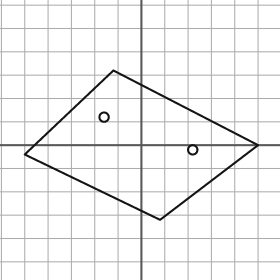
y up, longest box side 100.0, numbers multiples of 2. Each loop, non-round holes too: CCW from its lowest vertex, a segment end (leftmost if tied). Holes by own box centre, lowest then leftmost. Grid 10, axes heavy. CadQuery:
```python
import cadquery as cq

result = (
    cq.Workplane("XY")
    .moveTo(8.0, -32.0)
    .lineTo(50.0, 0.0)
    .lineTo(-12.0, 32.0)
    .lineTo(-50.0, -4.0)
    .close()
    .moveTo(22.0, -2.0)
    .circle(2.0)
    .moveTo(-16.0, 12.0)
    .circle(2.0)
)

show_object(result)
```